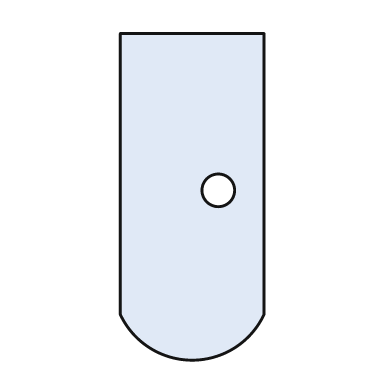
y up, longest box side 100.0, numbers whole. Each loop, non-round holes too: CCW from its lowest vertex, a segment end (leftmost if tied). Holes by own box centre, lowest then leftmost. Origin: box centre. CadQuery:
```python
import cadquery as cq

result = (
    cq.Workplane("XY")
    .moveTo(-22.0, -36.0)
    .threePointArc((0.0, -50.0), (22.0, -36.0))
    .lineTo(22.0, 50.0)
    .lineTo(-22.0, 50.0)
    .close()
    .moveTo(8.0, 2.0)
    .circle(5.0)
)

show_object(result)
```